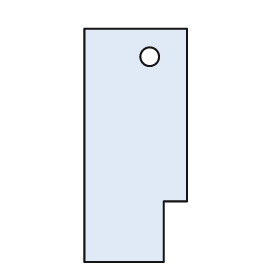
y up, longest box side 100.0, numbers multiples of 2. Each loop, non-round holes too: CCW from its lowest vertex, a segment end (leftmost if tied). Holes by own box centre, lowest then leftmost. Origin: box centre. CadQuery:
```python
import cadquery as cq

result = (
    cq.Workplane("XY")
    .moveTo(-22.0, -50.0)
    .lineTo(12.0, -50.0)
    .lineTo(12.0, -24.0)
    .lineTo(22.0, -24.0)
    .lineTo(22.0, 50.0)
    .lineTo(-22.0, 50.0)
    .close()
    .moveTo(6.0, 38.0)
    .circle(4.0)
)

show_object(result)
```